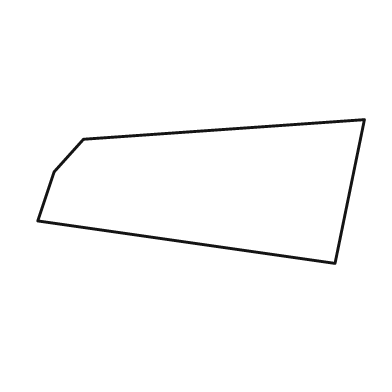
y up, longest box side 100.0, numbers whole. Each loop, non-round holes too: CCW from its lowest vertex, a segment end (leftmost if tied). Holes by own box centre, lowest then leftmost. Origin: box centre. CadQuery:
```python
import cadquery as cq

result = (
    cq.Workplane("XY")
    .moveTo(41.0, -22.0)
    .lineTo(50.0, 22.0)
    .lineTo(-36.0, 16.0)
    .lineTo(-45.0, 6.0)
    .lineTo(-50.0, -9.0)
    .close()
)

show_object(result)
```